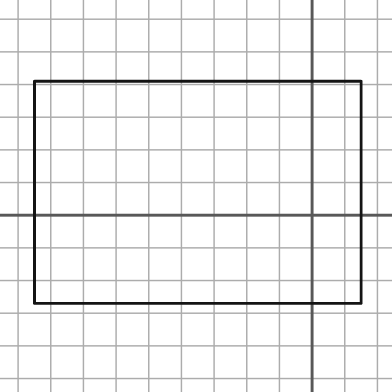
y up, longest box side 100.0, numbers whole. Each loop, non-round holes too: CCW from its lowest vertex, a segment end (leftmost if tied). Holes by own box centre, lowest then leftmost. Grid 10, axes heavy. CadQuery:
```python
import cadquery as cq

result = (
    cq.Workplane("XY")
    .moveTo(-85.0, -27.0)
    .lineTo(15.0, -27.0)
    .lineTo(15.0, 41.0)
    .lineTo(-85.0, 41.0)
    .close()
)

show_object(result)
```